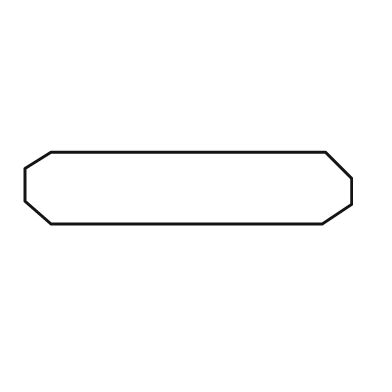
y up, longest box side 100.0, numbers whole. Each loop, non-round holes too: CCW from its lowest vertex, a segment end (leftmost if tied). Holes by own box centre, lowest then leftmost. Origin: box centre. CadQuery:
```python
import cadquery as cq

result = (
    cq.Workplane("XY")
    .moveTo(-42.0, -11.0)
    .lineTo(41.0, -11.0)
    .lineTo(50.0, -5.0)
    .lineTo(50.0, 3.0)
    .lineTo(42.0, 11.0)
    .lineTo(-42.0, 11.0)
    .lineTo(-50.0, 6.0)
    .lineTo(-50.0, -4.0)
    .close()
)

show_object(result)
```